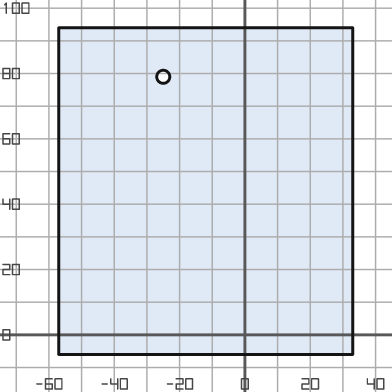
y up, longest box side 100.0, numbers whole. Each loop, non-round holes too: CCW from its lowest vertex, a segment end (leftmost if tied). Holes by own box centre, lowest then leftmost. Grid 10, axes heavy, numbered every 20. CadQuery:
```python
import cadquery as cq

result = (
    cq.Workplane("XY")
    .moveTo(-57.0, -6.0)
    .lineTo(33.0, -6.0)
    .lineTo(33.0, 94.0)
    .lineTo(-57.0, 94.0)
    .close()
    .moveTo(-25.0, 79.0)
    .circle(2.0)
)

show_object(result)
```